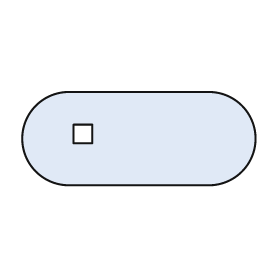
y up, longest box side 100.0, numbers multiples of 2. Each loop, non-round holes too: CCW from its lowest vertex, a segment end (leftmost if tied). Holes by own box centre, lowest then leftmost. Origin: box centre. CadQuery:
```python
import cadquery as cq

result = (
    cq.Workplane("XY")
    .moveTo(-30.0, -20.0)
    .lineTo(30.0, -20.0)
    .threePointArc((50.0, 0.0), (30.0, 20.0))
    .lineTo(-30.0, 20.0)
    .threePointArc((-50.0, 0.0), (-30.0, -20.0))
    .close()
    .moveTo(-28.0, -2.0)
    .lineTo(-20.0, -2.0)
    .lineTo(-20.0, 6.0)
    .lineTo(-28.0, 6.0)
    .close()
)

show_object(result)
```